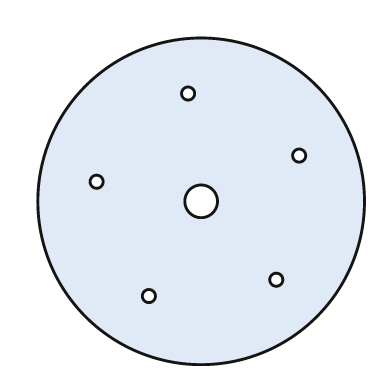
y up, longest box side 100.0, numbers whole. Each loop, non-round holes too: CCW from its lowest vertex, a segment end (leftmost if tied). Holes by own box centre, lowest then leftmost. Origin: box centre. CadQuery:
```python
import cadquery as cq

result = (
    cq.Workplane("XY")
    .moveTo(0.0, 0.0)
    .circle(50.0)
    .moveTo(-16.0, -29.0)
    .circle(2.0)
    .moveTo(23.0, -24.0)
    .circle(2.0)
    .moveTo(0.0, 0.0)
    .circle(5.0)
    .moveTo(-32.0, 6.0)
    .circle(2.0)
    .moveTo(30.0, 14.0)
    .circle(2.0)
    .moveTo(-4.0, 33.0)
    .circle(2.0)
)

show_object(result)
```